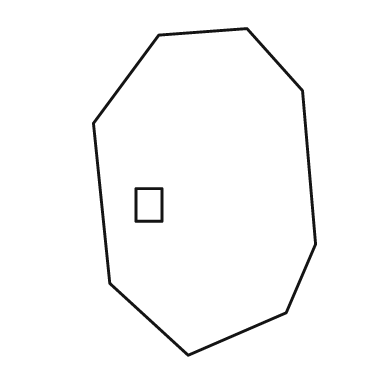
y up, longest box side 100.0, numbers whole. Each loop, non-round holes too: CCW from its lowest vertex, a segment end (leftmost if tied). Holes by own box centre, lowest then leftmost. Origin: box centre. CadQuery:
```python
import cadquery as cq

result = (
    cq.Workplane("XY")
    .moveTo(-5.0, -50.0)
    .lineTo(25.0, -37.0)
    .lineTo(34.0, -16.0)
    .lineTo(30.0, 31.0)
    .lineTo(13.0, 50.0)
    .lineTo(-14.0, 48.0)
    .lineTo(-34.0, 21.0)
    .lineTo(-29.0, -28.0)
    .close()
    .moveTo(-21.0, -9.0)
    .lineTo(-13.0, -9.0)
    .lineTo(-13.0, 1.0)
    .lineTo(-21.0, 1.0)
    .close()
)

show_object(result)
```